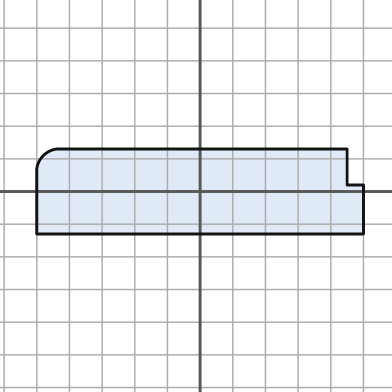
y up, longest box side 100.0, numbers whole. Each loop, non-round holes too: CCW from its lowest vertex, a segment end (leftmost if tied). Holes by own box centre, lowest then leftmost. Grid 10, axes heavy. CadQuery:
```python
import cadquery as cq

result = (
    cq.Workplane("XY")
    .moveTo(-50.0, -13.0)
    .lineTo(50.0, -13.0)
    .lineTo(50.0, 2.0)
    .lineTo(45.0, 2.0)
    .lineTo(45.0, 13.0)
    .lineTo(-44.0, 13.0)
    .threePointArc((-48.0, 11.0), (-50.0, 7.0))
    .close()
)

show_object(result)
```